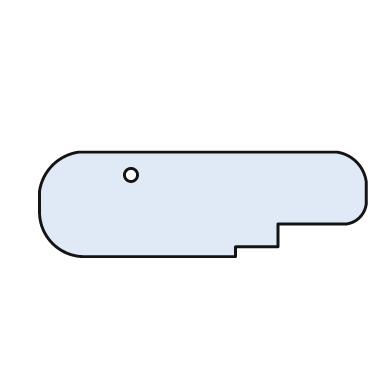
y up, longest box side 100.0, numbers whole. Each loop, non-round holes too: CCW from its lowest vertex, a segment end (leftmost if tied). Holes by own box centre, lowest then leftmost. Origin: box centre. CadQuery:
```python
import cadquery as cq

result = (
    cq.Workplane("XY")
    .moveTo(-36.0, -16.0)
    .lineTo(10.0, -16.0)
    .lineTo(10.0, -13.0)
    .lineTo(23.0, -13.0)
    .lineTo(23.0, -6.0)
    .lineTo(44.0, -6.0)
    .threePointArc((48.0, -4.0), (50.0, 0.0))
    .lineTo(50.0, 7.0)
    .threePointArc((47.0, 13.0), (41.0, 16.0))
    .lineTo(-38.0, 16.0)
    .threePointArc((-46.0, 12.0), (-50.0, 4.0))
    .lineTo(-50.0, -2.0)
    .threePointArc((-46.0, -12.0), (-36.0, -16.0))
    .close()
    .moveTo(-22.0, 9.0)
    .circle(2.0)
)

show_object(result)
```